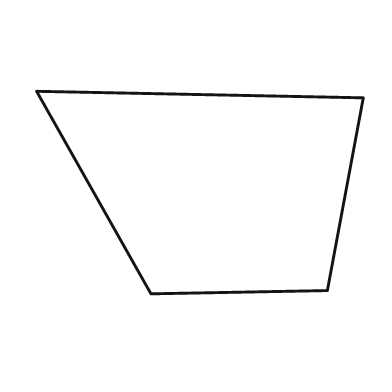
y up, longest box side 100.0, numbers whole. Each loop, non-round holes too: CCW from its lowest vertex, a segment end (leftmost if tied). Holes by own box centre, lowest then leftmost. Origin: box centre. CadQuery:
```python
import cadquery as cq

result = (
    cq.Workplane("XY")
    .moveTo(-15.0, -31.0)
    .lineTo(39.0, -30.0)
    .lineTo(50.0, 29.0)
    .lineTo(-50.0, 31.0)
    .close()
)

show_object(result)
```